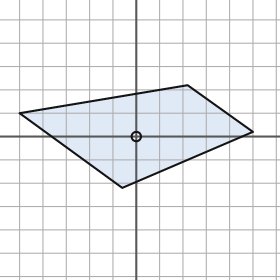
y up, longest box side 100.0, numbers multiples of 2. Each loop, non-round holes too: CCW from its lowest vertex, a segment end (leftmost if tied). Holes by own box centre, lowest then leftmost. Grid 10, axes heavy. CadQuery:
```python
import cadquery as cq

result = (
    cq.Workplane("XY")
    .moveTo(-6.0, -22.0)
    .lineTo(50.0, 2.0)
    .lineTo(22.0, 22.0)
    .lineTo(-50.0, 10.0)
    .close()
    .moveTo(0.0, 0.0)
    .circle(2.0)
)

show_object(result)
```